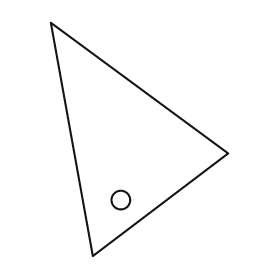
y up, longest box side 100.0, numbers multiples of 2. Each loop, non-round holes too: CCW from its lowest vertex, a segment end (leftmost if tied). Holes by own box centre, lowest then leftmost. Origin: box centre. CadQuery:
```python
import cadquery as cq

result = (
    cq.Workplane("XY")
    .moveTo(-20.0, -50.0)
    .lineTo(38.0, -6.0)
    .lineTo(-38.0, 50.0)
    .close()
    .moveTo(-8.0, -26.0)
    .circle(4.0)
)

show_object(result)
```